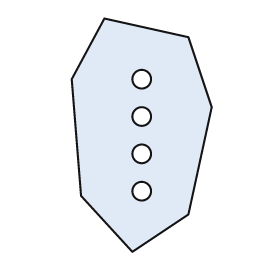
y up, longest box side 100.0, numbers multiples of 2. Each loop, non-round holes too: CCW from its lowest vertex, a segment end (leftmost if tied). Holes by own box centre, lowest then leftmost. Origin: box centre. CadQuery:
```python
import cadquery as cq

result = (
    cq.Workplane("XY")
    .moveTo(-4.0, -50.0)
    .lineTo(20.0, -34.0)
    .lineTo(30.0, 12.0)
    .lineTo(20.0, 42.0)
    .lineTo(-16.0, 50.0)
    .lineTo(-30.0, 24.0)
    .lineTo(-26.0, -26.0)
    .close()
    .moveTo(0.0, -24.0)
    .circle(4.0)
    .moveTo(0.0, -8.0)
    .circle(4.0)
    .moveTo(0.0, 8.0)
    .circle(4.0)
    .moveTo(0.0, 24.0)
    .circle(4.0)
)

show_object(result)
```